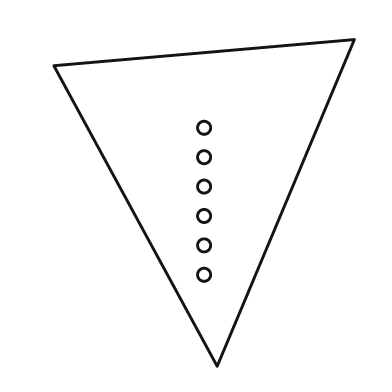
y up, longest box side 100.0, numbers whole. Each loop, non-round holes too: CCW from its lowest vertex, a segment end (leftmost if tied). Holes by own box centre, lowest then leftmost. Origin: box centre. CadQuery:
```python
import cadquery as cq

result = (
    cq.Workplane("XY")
    .moveTo(4.0, -50.0)
    .lineTo(46.0, 50.0)
    .lineTo(-46.0, 42.0)
    .close()
    .moveTo(0.0, -22.0)
    .circle(2.0)
    .moveTo(0.0, -13.0)
    .circle(2.0)
    .moveTo(0.0, -4.0)
    .circle(2.0)
    .moveTo(0.0, 5.0)
    .circle(2.0)
    .moveTo(0.0, 14.0)
    .circle(2.0)
    .moveTo(0.0, 23.0)
    .circle(2.0)
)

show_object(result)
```